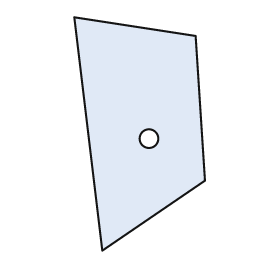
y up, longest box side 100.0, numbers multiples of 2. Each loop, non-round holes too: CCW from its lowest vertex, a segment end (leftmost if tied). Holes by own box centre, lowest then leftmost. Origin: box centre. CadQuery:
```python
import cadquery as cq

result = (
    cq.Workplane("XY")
    .moveTo(-16.0, -50.0)
    .lineTo(28.0, -20.0)
    .lineTo(24.0, 42.0)
    .lineTo(-28.0, 50.0)
    .close()
    .moveTo(4.0, -2.0)
    .circle(4.0)
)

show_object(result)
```